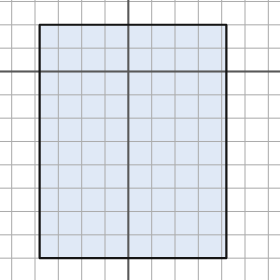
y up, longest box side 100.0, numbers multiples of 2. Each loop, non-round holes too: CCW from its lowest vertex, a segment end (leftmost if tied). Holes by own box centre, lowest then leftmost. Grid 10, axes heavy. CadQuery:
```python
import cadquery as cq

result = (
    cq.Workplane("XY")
    .moveTo(-38.0, -80.0)
    .lineTo(42.0, -80.0)
    .lineTo(42.0, 20.0)
    .lineTo(-38.0, 20.0)
    .close()
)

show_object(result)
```